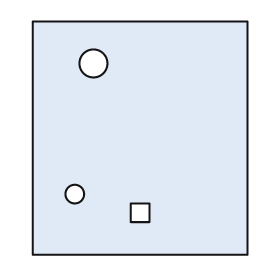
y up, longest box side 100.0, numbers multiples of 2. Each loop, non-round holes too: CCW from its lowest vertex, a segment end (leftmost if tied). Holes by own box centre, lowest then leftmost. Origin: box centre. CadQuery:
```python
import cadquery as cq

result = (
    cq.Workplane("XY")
    .moveTo(-46.0, -50.0)
    .lineTo(46.0, -50.0)
    .lineTo(46.0, 50.0)
    .lineTo(-46.0, 50.0)
    .close()
    .moveTo(-4.0, -36.0)
    .lineTo(4.0, -36.0)
    .lineTo(4.0, -28.0)
    .lineTo(-4.0, -28.0)
    .close()
    .moveTo(-28.0, -24.0)
    .circle(4.0)
    .moveTo(-20.0, 32.0)
    .circle(6.0)
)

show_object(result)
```